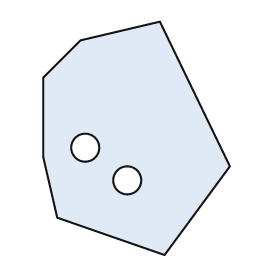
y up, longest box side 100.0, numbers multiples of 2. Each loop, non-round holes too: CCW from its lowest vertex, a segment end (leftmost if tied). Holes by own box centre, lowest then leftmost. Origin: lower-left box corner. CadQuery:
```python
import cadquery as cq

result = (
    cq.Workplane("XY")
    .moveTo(52.0, 0.0)
    .lineTo(80.0, 38.0)
    .lineTo(50.0, 100.0)
    .lineTo(16.0, 92.0)
    .lineTo(0.0, 76.0)
    .lineTo(0.0, 42.0)
    .lineTo(6.0, 16.0)
    .close()
    .moveTo(36.0, 32.0)
    .circle(6.0)
    .moveTo(18.0, 46.0)
    .circle(6.0)
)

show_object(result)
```